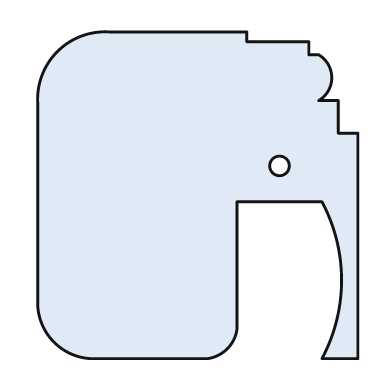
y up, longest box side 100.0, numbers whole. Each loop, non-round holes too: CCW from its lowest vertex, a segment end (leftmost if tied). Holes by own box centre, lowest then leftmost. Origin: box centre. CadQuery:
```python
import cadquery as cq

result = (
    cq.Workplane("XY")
    .moveTo(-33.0, -50.0)
    .lineTo(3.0, -50.0)
    .threePointArc((9.0, -47.0), (12.0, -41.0))
    .lineTo(12.0, -2.0)
    .lineTo(38.0, -2.0)
    .threePointArc((44.0, -26.0), (38.0, -50.0))
    .lineTo(49.0, -50.0)
    .lineTo(49.0, 19.0)
    .lineTo(43.0, 19.0)
    .lineTo(43.0, 29.0)
    .lineTo(37.0, 29.0)
    .threePointArc((41.0, 36.0), (37.0, 43.0))
    .lineTo(34.0, 43.0)
    .lineTo(34.0, 47.0)
    .lineTo(15.0, 47.0)
    .lineTo(15.0, 50.0)
    .lineTo(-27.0, 50.0)
    .threePointArc((-43.0, 44.0), (-49.0, 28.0))
    .lineTo(-49.0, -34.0)
    .threePointArc((-44.0, -45.0), (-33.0, -50.0))
    .close()
    .moveTo(25.0, 9.0)
    .circle(3.0)
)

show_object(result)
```